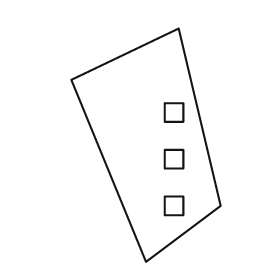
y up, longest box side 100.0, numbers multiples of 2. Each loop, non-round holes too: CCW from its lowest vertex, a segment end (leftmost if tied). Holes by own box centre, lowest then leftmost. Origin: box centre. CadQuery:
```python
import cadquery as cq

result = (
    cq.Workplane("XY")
    .moveTo(0.0, -50.0)
    .lineTo(32.0, -26.0)
    .lineTo(14.0, 50.0)
    .lineTo(-32.0, 28.0)
    .close()
    .moveTo(8.0, -30.0)
    .lineTo(16.0, -30.0)
    .lineTo(16.0, -22.0)
    .lineTo(8.0, -22.0)
    .close()
    .moveTo(8.0, -10.0)
    .lineTo(16.0, -10.0)
    .lineTo(16.0, -2.0)
    .lineTo(8.0, -2.0)
    .close()
    .moveTo(8.0, 10.0)
    .lineTo(16.0, 10.0)
    .lineTo(16.0, 18.0)
    .lineTo(8.0, 18.0)
    .close()
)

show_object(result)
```